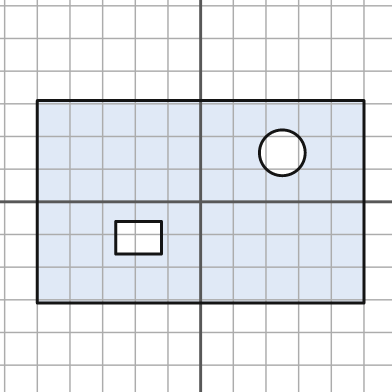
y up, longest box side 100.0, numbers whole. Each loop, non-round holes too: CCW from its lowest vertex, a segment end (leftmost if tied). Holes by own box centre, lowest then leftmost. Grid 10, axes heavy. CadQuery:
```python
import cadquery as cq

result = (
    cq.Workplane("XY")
    .moveTo(-50.0, -31.0)
    .lineTo(50.0, -31.0)
    .lineTo(50.0, 31.0)
    .lineTo(-50.0, 31.0)
    .close()
    .moveTo(-26.0, -16.0)
    .lineTo(-12.0, -16.0)
    .lineTo(-12.0, -6.0)
    .lineTo(-26.0, -6.0)
    .close()
    .moveTo(25.0, 15.0)
    .circle(7.0)
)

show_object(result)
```